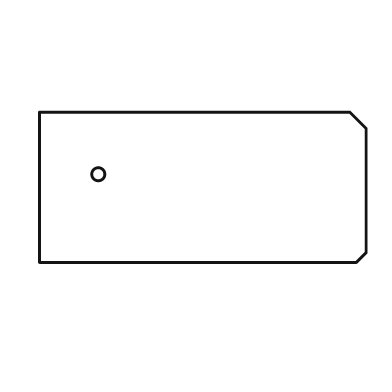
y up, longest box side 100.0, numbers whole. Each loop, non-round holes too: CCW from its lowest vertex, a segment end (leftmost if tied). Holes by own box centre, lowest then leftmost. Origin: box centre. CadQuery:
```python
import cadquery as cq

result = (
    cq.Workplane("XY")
    .moveTo(-50.0, -23.0)
    .lineTo(47.0, -23.0)
    .lineTo(50.0, -20.0)
    .lineTo(50.0, 18.0)
    .lineTo(45.0, 23.0)
    .lineTo(-50.0, 23.0)
    .close()
    .moveTo(-32.0, 4.0)
    .circle(2.0)
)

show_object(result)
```